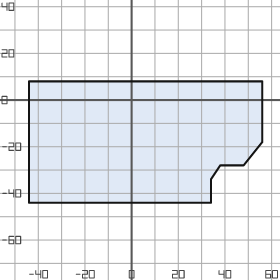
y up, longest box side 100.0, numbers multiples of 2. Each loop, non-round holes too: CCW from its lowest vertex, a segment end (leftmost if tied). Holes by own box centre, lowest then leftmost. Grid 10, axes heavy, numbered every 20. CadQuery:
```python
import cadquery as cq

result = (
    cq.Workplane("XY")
    .moveTo(-44.0, -44.0)
    .lineTo(34.0, -44.0)
    .lineTo(34.0, -34.0)
    .lineTo(38.0, -28.0)
    .lineTo(48.0, -28.0)
    .lineTo(56.0, -18.0)
    .lineTo(56.0, 8.0)
    .lineTo(-44.0, 8.0)
    .close()
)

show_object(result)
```